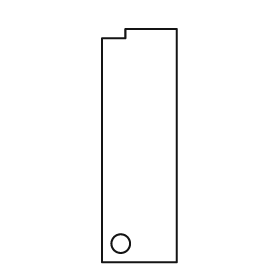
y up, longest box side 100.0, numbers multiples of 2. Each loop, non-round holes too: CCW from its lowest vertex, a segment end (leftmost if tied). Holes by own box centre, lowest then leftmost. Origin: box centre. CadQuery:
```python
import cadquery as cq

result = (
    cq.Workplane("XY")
    .moveTo(-16.0, -50.0)
    .lineTo(16.0, -50.0)
    .lineTo(16.0, 50.0)
    .lineTo(-6.0, 50.0)
    .lineTo(-6.0, 46.0)
    .lineTo(-16.0, 46.0)
    .close()
    .moveTo(-8.0, -42.0)
    .circle(4.0)
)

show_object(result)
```